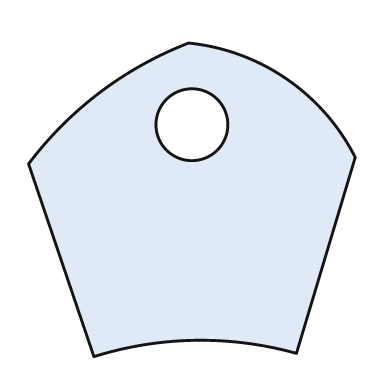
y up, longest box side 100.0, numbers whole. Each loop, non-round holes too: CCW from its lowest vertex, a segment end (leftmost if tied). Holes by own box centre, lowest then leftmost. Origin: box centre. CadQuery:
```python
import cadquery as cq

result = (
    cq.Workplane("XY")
    .moveTo(-30.0, -48.0)
    .threePointArc((1.0, -43.0), (32.0, -47.0))
    .lineTo(50.0, 13.0)
    .threePointArc((29.0, 37.0), (-1.0, 48.0))
    .threePointArc((-28.0, 33.0), (-50.0, 11.0))
    .close()
    .moveTo(0.0, 23.0)
    .circle(11.0)
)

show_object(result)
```